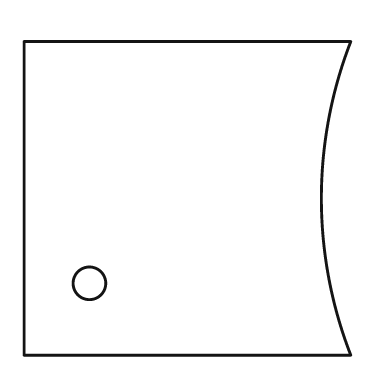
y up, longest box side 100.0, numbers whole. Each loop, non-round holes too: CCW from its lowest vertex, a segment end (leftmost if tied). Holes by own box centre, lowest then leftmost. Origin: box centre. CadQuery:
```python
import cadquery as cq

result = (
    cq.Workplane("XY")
    .moveTo(-50.0, -48.0)
    .lineTo(50.0, -48.0)
    .threePointArc((41.0, 0.0), (50.0, 48.0))
    .lineTo(-50.0, 48.0)
    .close()
    .moveTo(-30.0, -26.0)
    .circle(5.0)
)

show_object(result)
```